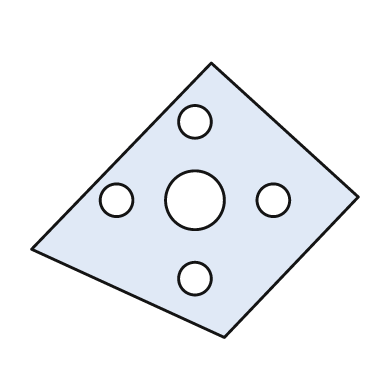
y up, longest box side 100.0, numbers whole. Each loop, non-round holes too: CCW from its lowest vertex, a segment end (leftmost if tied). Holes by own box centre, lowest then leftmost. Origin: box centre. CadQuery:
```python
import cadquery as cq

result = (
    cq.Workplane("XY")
    .moveTo(9.0, -42.0)
    .lineTo(50.0, 1.0)
    .lineTo(5.0, 42.0)
    .lineTo(-50.0, -15.0)
    .close()
    .moveTo(0.0, -24.0)
    .circle(5.0)
    .moveTo(-24.0, 0.0)
    .circle(5.0)
    .moveTo(0.0, 0.0)
    .circle(9.0)
    .moveTo(24.0, 0.0)
    .circle(5.0)
    .moveTo(0.0, 24.0)
    .circle(5.0)
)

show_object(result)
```